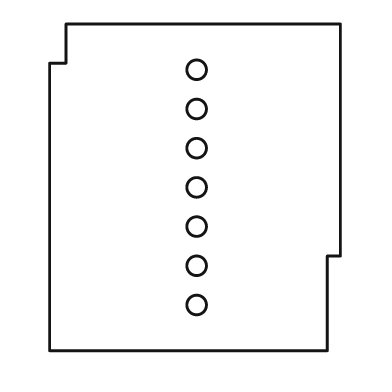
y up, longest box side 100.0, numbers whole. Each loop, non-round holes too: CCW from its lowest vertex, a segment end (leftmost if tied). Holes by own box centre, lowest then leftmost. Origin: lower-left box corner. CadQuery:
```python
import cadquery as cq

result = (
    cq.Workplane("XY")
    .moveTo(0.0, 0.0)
    .lineTo(85.0, 0.0)
    .lineTo(85.0, 29.0)
    .lineTo(89.0, 29.0)
    .lineTo(89.0, 100.0)
    .lineTo(5.0, 100.0)
    .lineTo(5.0, 88.0)
    .lineTo(0.0, 88.0)
    .close()
    .moveTo(45.0, 14.0)
    .circle(3.0)
    .moveTo(45.0, 26.0)
    .circle(3.0)
    .moveTo(45.0, 38.0)
    .circle(3.0)
    .moveTo(45.0, 50.0)
    .circle(3.0)
    .moveTo(45.0, 62.0)
    .circle(3.0)
    .moveTo(45.0, 74.0)
    .circle(3.0)
    .moveTo(45.0, 86.0)
    .circle(3.0)
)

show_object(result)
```